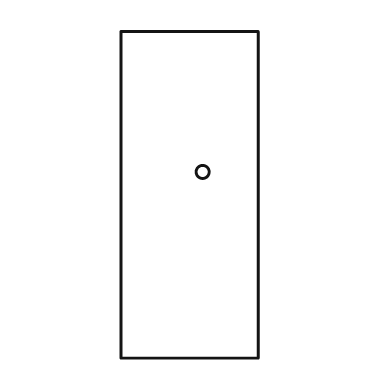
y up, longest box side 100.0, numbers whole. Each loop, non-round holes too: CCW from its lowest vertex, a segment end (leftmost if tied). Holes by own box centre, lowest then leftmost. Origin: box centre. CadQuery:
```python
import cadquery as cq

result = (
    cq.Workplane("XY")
    .moveTo(-21.0, -50.0)
    .lineTo(21.0, -50.0)
    .lineTo(21.0, 50.0)
    .lineTo(-21.0, 50.0)
    .close()
    .moveTo(4.0, 7.0)
    .circle(2.0)
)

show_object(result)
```